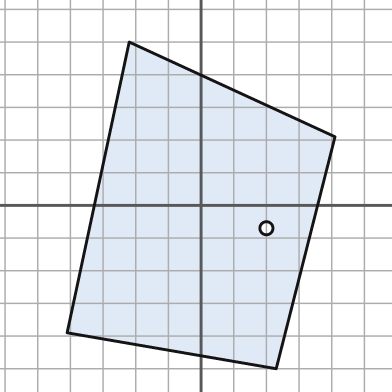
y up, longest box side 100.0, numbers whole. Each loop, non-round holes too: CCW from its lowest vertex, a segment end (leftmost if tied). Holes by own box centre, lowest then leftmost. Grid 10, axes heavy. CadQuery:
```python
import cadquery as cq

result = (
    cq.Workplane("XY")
    .moveTo(23.0, -50.0)
    .lineTo(41.0, 21.0)
    .lineTo(-22.0, 50.0)
    .lineTo(-41.0, -39.0)
    .close()
    .moveTo(20.0, -7.0)
    .circle(2.0)
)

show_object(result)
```